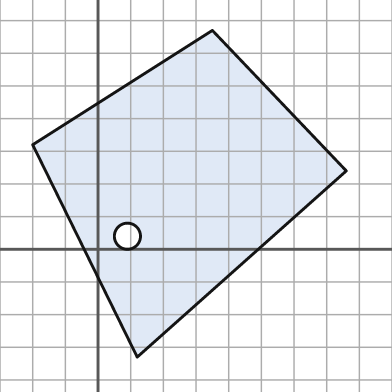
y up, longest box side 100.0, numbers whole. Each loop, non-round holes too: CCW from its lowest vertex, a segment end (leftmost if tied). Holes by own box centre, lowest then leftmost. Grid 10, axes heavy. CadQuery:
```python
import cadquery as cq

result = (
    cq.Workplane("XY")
    .moveTo(12.0, -33.0)
    .lineTo(76.0, 24.0)
    .lineTo(35.0, 67.0)
    .lineTo(-20.0, 32.0)
    .close()
    .moveTo(9.0, 4.0)
    .circle(4.0)
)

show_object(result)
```